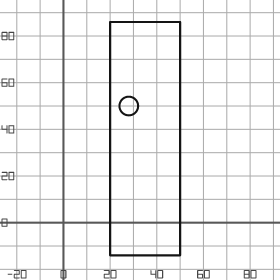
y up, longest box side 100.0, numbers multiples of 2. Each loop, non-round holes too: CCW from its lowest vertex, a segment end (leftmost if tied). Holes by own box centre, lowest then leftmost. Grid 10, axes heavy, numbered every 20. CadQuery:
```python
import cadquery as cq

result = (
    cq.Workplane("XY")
    .moveTo(20.0, -14.0)
    .lineTo(50.0, -14.0)
    .lineTo(50.0, 86.0)
    .lineTo(20.0, 86.0)
    .close()
    .moveTo(28.0, 50.0)
    .circle(4.0)
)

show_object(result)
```